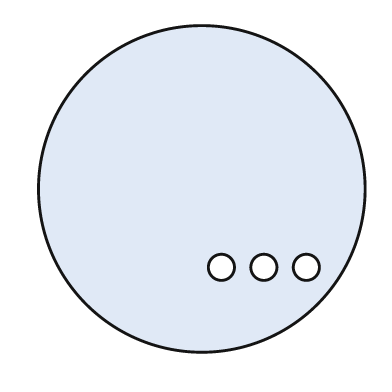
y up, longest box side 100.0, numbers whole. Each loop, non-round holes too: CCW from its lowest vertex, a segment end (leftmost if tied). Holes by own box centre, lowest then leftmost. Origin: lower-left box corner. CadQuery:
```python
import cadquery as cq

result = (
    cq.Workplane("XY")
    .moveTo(50.0, 50.0)
    .circle(50.0)
    .moveTo(56.0, 26.0)
    .circle(4.0)
    .moveTo(69.0, 26.0)
    .circle(4.0)
    .moveTo(82.0, 26.0)
    .circle(4.0)
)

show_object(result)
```